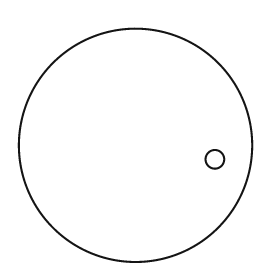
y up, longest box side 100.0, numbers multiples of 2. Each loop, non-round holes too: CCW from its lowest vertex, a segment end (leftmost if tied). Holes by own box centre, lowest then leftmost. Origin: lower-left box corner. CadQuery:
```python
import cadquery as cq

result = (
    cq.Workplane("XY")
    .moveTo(50.0, 50.0)
    .circle(50.0)
    .moveTo(84.0, 44.0)
    .circle(4.0)
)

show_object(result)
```